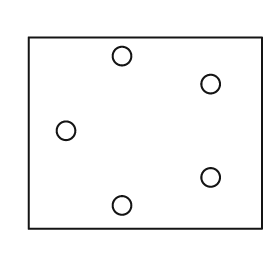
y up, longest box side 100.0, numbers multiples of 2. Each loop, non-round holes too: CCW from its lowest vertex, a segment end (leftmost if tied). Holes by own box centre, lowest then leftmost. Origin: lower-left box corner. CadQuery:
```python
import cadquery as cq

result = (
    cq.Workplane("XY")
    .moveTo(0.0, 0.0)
    .lineTo(100.0, 0.0)
    .lineTo(100.0, 82.0)
    .lineTo(0.0, 82.0)
    .close()
    .moveTo(40.0, 10.0)
    .circle(4.0)
    .moveTo(78.0, 22.0)
    .circle(4.0)
    .moveTo(16.0, 42.0)
    .circle(4.0)
    .moveTo(78.0, 62.0)
    .circle(4.0)
    .moveTo(40.0, 74.0)
    .circle(4.0)
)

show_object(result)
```